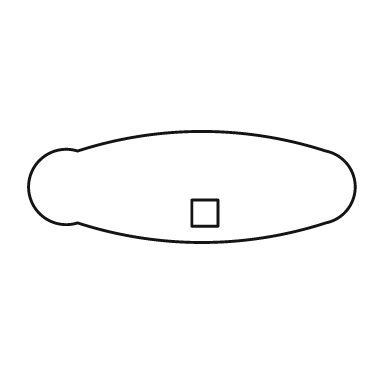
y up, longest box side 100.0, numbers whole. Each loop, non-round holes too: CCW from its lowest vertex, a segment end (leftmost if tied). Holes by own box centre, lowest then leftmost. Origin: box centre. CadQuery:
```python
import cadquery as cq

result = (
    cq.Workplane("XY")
    .moveTo(-35.0, -11.0)
    .threePointArc((3.0, -17.0), (41.0, -11.0))
    .threePointArc((50.0, 0.0), (41.0, 11.0))
    .threePointArc((3.0, 17.0), (-35.0, 11.0))
    .threePointArc((-50.0, 0.0), (-35.0, -11.0))
    .close()
    .moveTo(0.0, -12.0)
    .lineTo(8.0, -12.0)
    .lineTo(8.0, -4.0)
    .lineTo(0.0, -4.0)
    .close()
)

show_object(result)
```